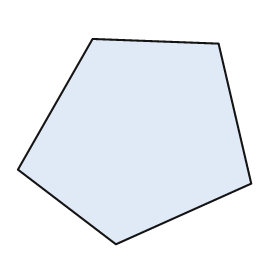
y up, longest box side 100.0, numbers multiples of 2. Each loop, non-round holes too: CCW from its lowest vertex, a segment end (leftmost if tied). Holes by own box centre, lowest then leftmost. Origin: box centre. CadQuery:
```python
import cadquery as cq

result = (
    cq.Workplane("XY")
    .moveTo(-8.0, -44.0)
    .lineTo(50.0, -18.0)
    .lineTo(36.0, 42.0)
    .lineTo(-18.0, 44.0)
    .lineTo(-50.0, -12.0)
    .close()
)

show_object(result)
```